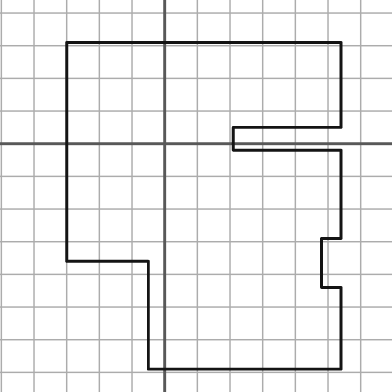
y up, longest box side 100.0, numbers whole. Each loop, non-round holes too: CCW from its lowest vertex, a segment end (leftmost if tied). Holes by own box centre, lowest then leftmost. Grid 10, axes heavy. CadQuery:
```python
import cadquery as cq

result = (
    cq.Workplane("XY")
    .moveTo(-5.0, -69.0)
    .lineTo(54.0, -69.0)
    .lineTo(54.0, -44.0)
    .lineTo(48.0, -44.0)
    .lineTo(48.0, -29.0)
    .lineTo(54.0, -29.0)
    .lineTo(54.0, -2.0)
    .lineTo(21.0, -2.0)
    .lineTo(21.0, 5.0)
    .lineTo(54.0, 5.0)
    .lineTo(54.0, 31.0)
    .lineTo(-30.0, 31.0)
    .lineTo(-30.0, -36.0)
    .lineTo(-5.0, -36.0)
    .close()
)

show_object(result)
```